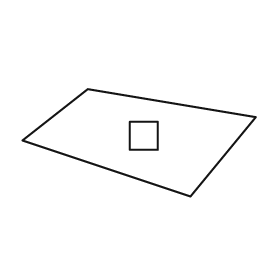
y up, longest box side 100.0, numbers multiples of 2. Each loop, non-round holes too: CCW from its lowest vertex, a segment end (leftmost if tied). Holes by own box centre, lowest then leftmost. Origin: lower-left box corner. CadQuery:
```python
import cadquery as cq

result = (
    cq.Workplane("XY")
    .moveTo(72.0, 0.0)
    .lineTo(100.0, 34.0)
    .lineTo(28.0, 46.0)
    .lineTo(0.0, 24.0)
    .close()
    .moveTo(46.0, 20.0)
    .lineTo(58.0, 20.0)
    .lineTo(58.0, 32.0)
    .lineTo(46.0, 32.0)
    .close()
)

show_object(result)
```